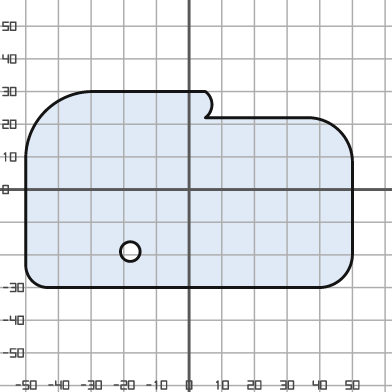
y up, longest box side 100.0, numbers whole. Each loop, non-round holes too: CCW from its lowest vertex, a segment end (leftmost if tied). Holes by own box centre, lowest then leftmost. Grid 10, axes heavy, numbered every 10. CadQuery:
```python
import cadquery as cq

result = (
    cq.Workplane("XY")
    .moveTo(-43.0, -30.0)
    .lineTo(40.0, -30.0)
    .threePointArc((47.0, -27.0), (50.0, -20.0))
    .lineTo(50.0, 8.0)
    .threePointArc((46.0, 18.0), (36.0, 22.0))
    .lineTo(5.0, 22.0)
    .threePointArc((7.0, 26.0), (5.0, 30.0))
    .lineTo(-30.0, 30.0)
    .threePointArc((-44.0, 24.0), (-50.0, 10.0))
    .lineTo(-50.0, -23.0)
    .threePointArc((-48.0, -28.0), (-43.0, -30.0))
    .close()
    .moveTo(-18.0, -19.0)
    .circle(3.0)
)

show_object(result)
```